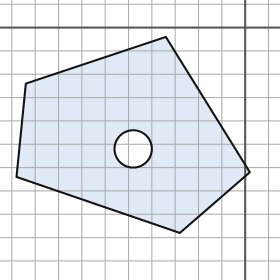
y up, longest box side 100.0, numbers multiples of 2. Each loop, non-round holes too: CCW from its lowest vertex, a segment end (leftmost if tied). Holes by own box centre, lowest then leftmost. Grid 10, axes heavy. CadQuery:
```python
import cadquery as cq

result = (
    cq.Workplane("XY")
    .moveTo(-28.0, -88.0)
    .lineTo(2.0, -62.0)
    .lineTo(-34.0, -4.0)
    .lineTo(-94.0, -24.0)
    .lineTo(-98.0, -64.0)
    .close()
    .moveTo(-48.0, -52.0)
    .circle(8.0)
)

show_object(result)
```